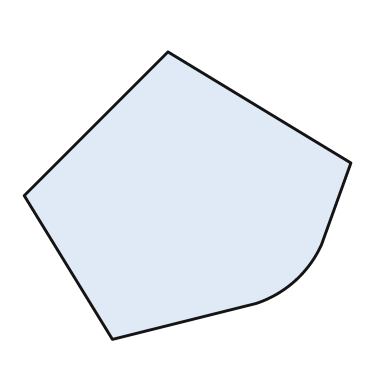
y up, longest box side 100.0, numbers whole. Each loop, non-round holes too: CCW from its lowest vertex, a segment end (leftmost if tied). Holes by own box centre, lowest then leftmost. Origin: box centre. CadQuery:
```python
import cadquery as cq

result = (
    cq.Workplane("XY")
    .moveTo(-23.0, -44.0)
    .lineTo(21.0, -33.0)
    .threePointArc((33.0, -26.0), (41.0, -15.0))
    .lineTo(50.0, 10.0)
    .lineTo(-6.0, 44.0)
    .lineTo(-50.0, 0.0)
    .close()
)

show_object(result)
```